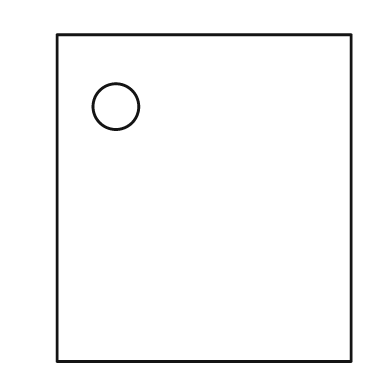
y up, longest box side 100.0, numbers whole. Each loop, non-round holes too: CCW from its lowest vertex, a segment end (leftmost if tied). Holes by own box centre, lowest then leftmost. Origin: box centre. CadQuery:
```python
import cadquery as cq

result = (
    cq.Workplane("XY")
    .moveTo(-45.0, -50.0)
    .lineTo(45.0, -50.0)
    .lineTo(45.0, 50.0)
    .lineTo(-45.0, 50.0)
    .close()
    .moveTo(-27.0, 28.0)
    .circle(7.0)
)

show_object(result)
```